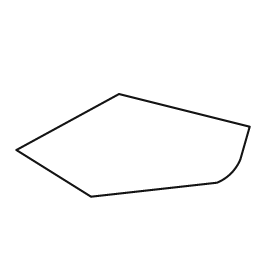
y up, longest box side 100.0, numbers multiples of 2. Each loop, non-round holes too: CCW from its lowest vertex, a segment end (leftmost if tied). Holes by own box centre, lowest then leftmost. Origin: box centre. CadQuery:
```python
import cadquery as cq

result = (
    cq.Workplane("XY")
    .moveTo(-18.0, -22.0)
    .lineTo(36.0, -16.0)
    .threePointArc((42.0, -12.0), (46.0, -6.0))
    .lineTo(50.0, 8.0)
    .lineTo(-6.0, 22.0)
    .lineTo(-50.0, -2.0)
    .close()
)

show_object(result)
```